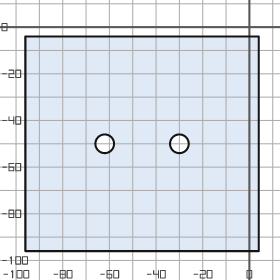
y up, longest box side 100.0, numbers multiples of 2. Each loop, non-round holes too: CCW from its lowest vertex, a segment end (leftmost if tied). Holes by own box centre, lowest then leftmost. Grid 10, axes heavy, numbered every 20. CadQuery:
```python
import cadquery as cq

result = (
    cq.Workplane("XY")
    .moveTo(-96.0, -96.0)
    .lineTo(4.0, -96.0)
    .lineTo(4.0, -4.0)
    .lineTo(-96.0, -4.0)
    .close()
    .moveTo(-62.0, -50.0)
    .circle(4.0)
    .moveTo(-30.0, -50.0)
    .circle(4.0)
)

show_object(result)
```